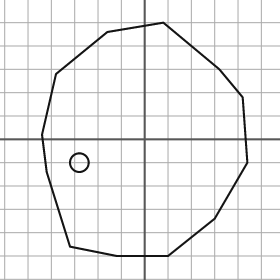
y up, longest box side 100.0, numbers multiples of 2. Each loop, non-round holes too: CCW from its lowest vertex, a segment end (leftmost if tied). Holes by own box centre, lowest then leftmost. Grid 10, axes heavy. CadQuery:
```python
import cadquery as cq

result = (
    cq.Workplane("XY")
    .moveTo(-12.0, -50.0)
    .lineTo(10.0, -50.0)
    .lineTo(30.0, -34.0)
    .lineTo(44.0, -10.0)
    .lineTo(42.0, 18.0)
    .lineTo(32.0, 30.0)
    .lineTo(8.0, 50.0)
    .lineTo(-16.0, 46.0)
    .lineTo(-38.0, 28.0)
    .lineTo(-44.0, 2.0)
    .lineTo(-42.0, -14.0)
    .lineTo(-32.0, -46.0)
    .close()
    .moveTo(-28.0, -10.0)
    .circle(4.0)
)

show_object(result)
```